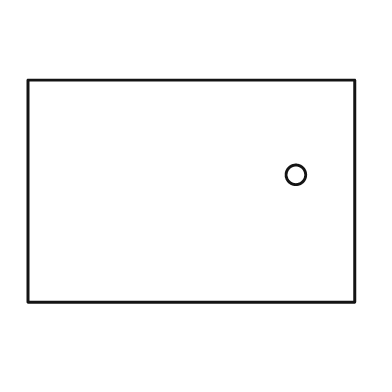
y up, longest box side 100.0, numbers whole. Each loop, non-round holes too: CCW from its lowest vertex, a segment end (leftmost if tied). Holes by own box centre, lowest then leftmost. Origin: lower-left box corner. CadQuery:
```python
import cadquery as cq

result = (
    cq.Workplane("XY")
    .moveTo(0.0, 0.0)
    .lineTo(100.0, 0.0)
    .lineTo(100.0, 68.0)
    .lineTo(0.0, 68.0)
    .close()
    .moveTo(82.0, 39.0)
    .circle(3.0)
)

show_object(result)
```